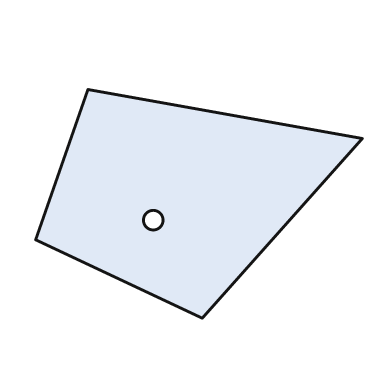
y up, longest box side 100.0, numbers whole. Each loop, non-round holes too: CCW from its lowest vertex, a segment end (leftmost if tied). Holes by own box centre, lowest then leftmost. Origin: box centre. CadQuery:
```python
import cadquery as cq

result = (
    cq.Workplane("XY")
    .moveTo(1.0, -35.0)
    .lineTo(50.0, 20.0)
    .lineTo(-34.0, 35.0)
    .lineTo(-50.0, -11.0)
    .close()
    .moveTo(-14.0, -5.0)
    .circle(3.0)
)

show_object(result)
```